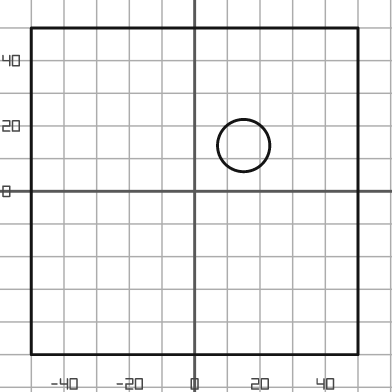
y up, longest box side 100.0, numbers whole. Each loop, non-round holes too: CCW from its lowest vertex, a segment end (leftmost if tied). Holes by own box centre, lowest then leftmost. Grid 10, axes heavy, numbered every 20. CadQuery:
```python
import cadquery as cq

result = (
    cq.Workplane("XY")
    .moveTo(-50.0, -50.0)
    .lineTo(50.0, -50.0)
    .lineTo(50.0, 50.0)
    .lineTo(-50.0, 50.0)
    .close()
    .moveTo(15.0, 14.0)
    .circle(8.0)
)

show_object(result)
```